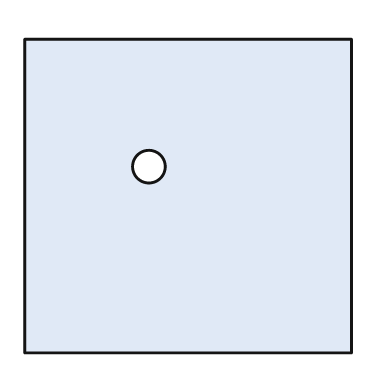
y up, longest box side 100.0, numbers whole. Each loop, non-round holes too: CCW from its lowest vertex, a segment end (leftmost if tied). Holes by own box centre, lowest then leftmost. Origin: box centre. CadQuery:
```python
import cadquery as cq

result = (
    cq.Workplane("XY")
    .moveTo(-50.0, -48.0)
    .lineTo(50.0, -48.0)
    .lineTo(50.0, 48.0)
    .lineTo(-50.0, 48.0)
    .close()
    .moveTo(-12.0, 9.0)
    .circle(5.0)
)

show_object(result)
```